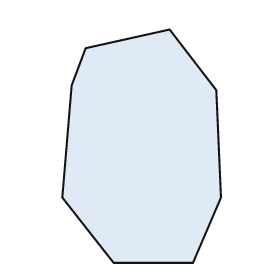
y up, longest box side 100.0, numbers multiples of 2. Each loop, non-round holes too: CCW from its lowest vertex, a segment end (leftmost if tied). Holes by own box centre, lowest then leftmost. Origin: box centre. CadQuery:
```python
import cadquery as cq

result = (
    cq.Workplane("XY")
    .moveTo(-12.0, -50.0)
    .lineTo(22.0, -50.0)
    .lineTo(34.0, -22.0)
    .lineTo(32.0, 24.0)
    .lineTo(12.0, 50.0)
    .lineTo(-24.0, 42.0)
    .lineTo(-30.0, 26.0)
    .lineTo(-34.0, -22.0)
    .close()
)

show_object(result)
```